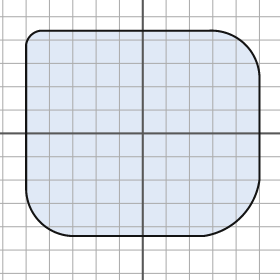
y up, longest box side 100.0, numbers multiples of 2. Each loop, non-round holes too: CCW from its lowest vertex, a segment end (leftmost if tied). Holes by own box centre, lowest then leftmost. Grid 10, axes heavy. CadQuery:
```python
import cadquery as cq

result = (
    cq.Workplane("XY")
    .moveTo(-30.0, -44.0)
    .lineTo(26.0, -44.0)
    .threePointArc((42.0, -36.0), (50.0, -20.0))
    .lineTo(50.0, 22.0)
    .threePointArc((44.0, 38.0), (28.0, 44.0))
    .lineTo(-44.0, 44.0)
    .threePointArc((-48.0, 42.0), (-50.0, 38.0))
    .lineTo(-50.0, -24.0)
    .threePointArc((-44.0, -38.0), (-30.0, -44.0))
    .close()
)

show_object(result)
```